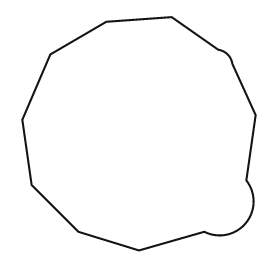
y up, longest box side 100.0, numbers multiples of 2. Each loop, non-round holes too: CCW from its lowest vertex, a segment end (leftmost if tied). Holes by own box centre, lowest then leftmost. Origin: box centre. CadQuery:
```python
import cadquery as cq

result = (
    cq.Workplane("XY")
    .moveTo(0.0, -50.0)
    .lineTo(28.0, -42.0)
    .threePointArc((46.0, -38.0), (46.0, -20.0))
    .lineTo(50.0, 8.0)
    .lineTo(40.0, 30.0)
    .threePointArc((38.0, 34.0), (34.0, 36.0))
    .lineTo(14.0, 50.0)
    .lineTo(-14.0, 48.0)
    .lineTo(-38.0, 34.0)
    .lineTo(-50.0, 6.0)
    .lineTo(-46.0, -22.0)
    .lineTo(-26.0, -42.0)
    .close()
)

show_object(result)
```